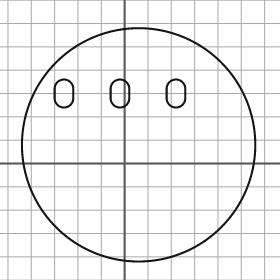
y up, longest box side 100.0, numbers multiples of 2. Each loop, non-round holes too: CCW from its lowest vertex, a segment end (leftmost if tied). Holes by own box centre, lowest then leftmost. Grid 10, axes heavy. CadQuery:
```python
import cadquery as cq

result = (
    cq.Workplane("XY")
    .moveTo(6.0, 8.0)
    .circle(50.0)
    .moveTo(-30.0, 28.0)
    .threePointArc((-26.0, 24.0), (-22.0, 28.0))
    .lineTo(-22.0, 32.0)
    .threePointArc((-26.0, 36.0), (-30.0, 32.0))
    .close()
    .moveTo(-6.0, 28.0)
    .threePointArc((-2.0, 24.0), (2.0, 28.0))
    .lineTo(2.0, 32.0)
    .threePointArc((-2.0, 36.0), (-6.0, 32.0))
    .close()
    .moveTo(18.0, 28.0)
    .threePointArc((22.0, 24.0), (26.0, 28.0))
    .lineTo(26.0, 32.0)
    .threePointArc((22.0, 36.0), (18.0, 32.0))
    .close()
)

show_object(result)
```